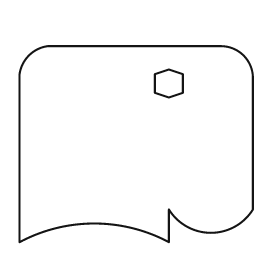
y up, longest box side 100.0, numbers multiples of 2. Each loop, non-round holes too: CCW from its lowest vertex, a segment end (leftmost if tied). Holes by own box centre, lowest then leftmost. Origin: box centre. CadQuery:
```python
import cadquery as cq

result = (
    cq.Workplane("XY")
    .moveTo(-50.0, -42.0)
    .threePointArc((-18.0, -34.0), (14.0, -42.0))
    .lineTo(14.0, -28.0)
    .threePointArc((32.0, -38.0), (50.0, -28.0))
    .lineTo(50.0, 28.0)
    .threePointArc((46.0, 38.0), (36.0, 42.0))
    .lineTo(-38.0, 42.0)
    .threePointArc((-46.0, 38.0), (-50.0, 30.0))
    .close()
    .moveTo(14.0, 20.0)
    .lineTo(20.0, 22.0)
    .lineTo(20.0, 30.0)
    .lineTo(14.0, 32.0)
    .lineTo(8.0, 30.0)
    .lineTo(8.0, 22.0)
    .close()
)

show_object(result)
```